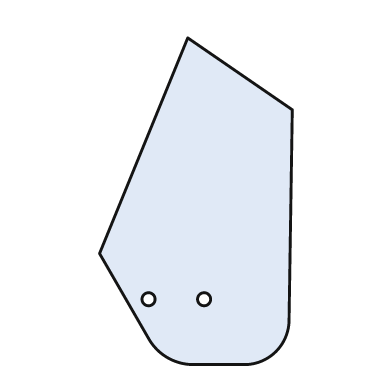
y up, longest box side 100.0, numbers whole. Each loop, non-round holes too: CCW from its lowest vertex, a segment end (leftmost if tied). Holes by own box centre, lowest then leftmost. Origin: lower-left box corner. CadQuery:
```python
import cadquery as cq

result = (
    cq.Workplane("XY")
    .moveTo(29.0, 0.0)
    .lineTo(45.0, 0.0)
    .threePointArc((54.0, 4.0), (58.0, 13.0))
    .lineTo(59.0, 78.0)
    .lineTo(27.0, 100.0)
    .lineTo(0.0, 34.0)
    .lineTo(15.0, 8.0)
    .threePointArc((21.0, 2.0), (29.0, 0.0))
    .close()
    .moveTo(15.0, 20.0)
    .circle(2.0)
    .moveTo(32.0, 20.0)
    .circle(2.0)
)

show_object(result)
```